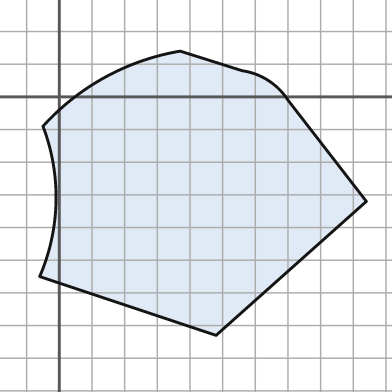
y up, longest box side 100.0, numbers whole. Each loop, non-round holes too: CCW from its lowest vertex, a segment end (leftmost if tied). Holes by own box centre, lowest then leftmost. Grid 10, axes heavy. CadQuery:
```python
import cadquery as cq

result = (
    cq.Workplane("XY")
    .moveTo(48.0, -73.0)
    .lineTo(94.0, -32.0)
    .lineTo(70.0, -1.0)
    .threePointArc((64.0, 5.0), (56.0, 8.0))
    .lineTo(37.0, 14.0)
    .threePointArc((14.0, 6.0), (-5.0, -9.0))
    .threePointArc((-1.0, -32.0), (-6.0, -55.0))
    .close()
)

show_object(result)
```